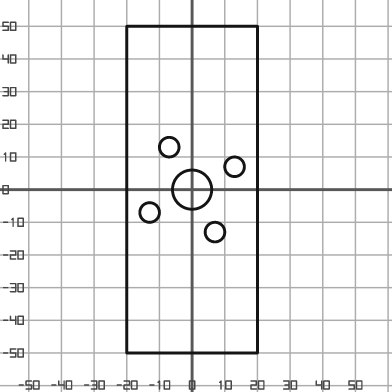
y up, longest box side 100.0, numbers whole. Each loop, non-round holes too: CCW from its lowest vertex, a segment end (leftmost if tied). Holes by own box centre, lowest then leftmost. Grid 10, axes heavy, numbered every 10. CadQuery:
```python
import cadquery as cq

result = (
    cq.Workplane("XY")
    .moveTo(-20.0, -50.0)
    .lineTo(20.0, -50.0)
    .lineTo(20.0, 50.0)
    .lineTo(-20.0, 50.0)
    .close()
    .moveTo(7.0, -13.0)
    .circle(3.0)
    .moveTo(-13.0, -7.0)
    .circle(3.0)
    .moveTo(0.0, 0.0)
    .circle(6.0)
    .moveTo(13.0, 7.0)
    .circle(3.0)
    .moveTo(-7.0, 13.0)
    .circle(3.0)
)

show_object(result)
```